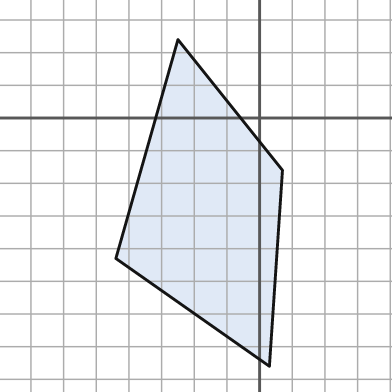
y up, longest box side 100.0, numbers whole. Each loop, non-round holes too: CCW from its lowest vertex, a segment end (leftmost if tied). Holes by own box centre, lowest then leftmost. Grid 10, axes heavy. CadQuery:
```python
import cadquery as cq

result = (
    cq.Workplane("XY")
    .moveTo(3.0, -76.0)
    .lineTo(7.0, -16.0)
    .lineTo(-25.0, 24.0)
    .lineTo(-44.0, -43.0)
    .close()
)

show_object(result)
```